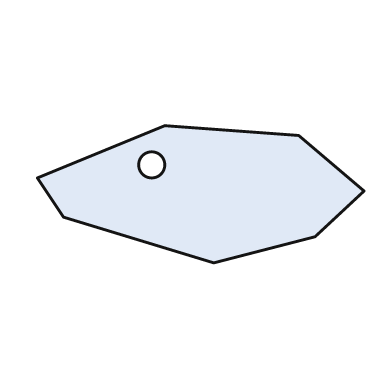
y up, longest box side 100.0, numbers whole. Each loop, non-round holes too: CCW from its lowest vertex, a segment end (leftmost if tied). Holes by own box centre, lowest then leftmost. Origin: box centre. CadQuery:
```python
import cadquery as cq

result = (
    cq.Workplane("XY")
    .moveTo(4.0, -21.0)
    .lineTo(35.0, -13.0)
    .lineTo(50.0, 1.0)
    .lineTo(30.0, 18.0)
    .lineTo(-11.0, 21.0)
    .lineTo(-50.0, 5.0)
    .lineTo(-42.0, -7.0)
    .close()
    .moveTo(-15.0, 9.0)
    .circle(4.0)
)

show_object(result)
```